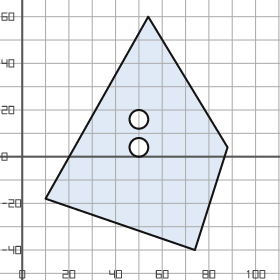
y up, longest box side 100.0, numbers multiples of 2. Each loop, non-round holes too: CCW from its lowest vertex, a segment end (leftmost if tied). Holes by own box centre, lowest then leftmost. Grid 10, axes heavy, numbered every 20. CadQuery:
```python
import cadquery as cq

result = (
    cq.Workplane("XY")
    .moveTo(74.0, -40.0)
    .lineTo(88.0, 4.0)
    .lineTo(54.0, 60.0)
    .lineTo(10.0, -18.0)
    .close()
    .moveTo(50.0, 4.0)
    .circle(4.0)
    .moveTo(50.0, 16.0)
    .circle(4.0)
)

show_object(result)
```